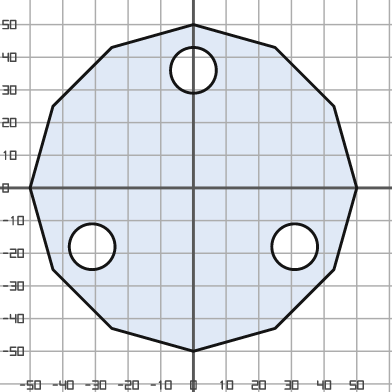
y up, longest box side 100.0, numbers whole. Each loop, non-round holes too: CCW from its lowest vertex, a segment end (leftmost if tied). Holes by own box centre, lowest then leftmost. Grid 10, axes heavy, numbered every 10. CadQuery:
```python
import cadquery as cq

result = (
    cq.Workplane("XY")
    .moveTo(0.0, -50.0)
    .lineTo(25.0, -43.0)
    .lineTo(43.0, -25.0)
    .lineTo(50.0, 0.0)
    .lineTo(43.0, 25.0)
    .lineTo(25.0, 43.0)
    .lineTo(0.0, 50.0)
    .lineTo(-25.0, 43.0)
    .lineTo(-43.0, 25.0)
    .lineTo(-50.0, 0.0)
    .lineTo(-43.0, -25.0)
    .lineTo(-25.0, -43.0)
    .close()
    .moveTo(-31.0, -18.0)
    .circle(7.0)
    .moveTo(31.0, -18.0)
    .circle(7.0)
    .moveTo(0.0, 36.0)
    .circle(7.0)
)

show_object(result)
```